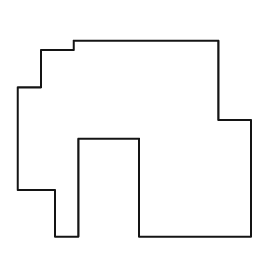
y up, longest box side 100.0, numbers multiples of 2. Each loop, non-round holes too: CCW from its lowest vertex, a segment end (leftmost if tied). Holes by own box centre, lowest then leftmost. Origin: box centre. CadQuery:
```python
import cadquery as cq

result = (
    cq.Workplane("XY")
    .moveTo(-34.0, -42.0)
    .lineTo(-24.0, -42.0)
    .lineTo(-24.0, 0.0)
    .lineTo(2.0, 0.0)
    .lineTo(2.0, -42.0)
    .lineTo(50.0, -42.0)
    .lineTo(50.0, 8.0)
    .lineTo(36.0, 8.0)
    .lineTo(36.0, 42.0)
    .lineTo(-26.0, 42.0)
    .lineTo(-26.0, 38.0)
    .lineTo(-40.0, 38.0)
    .lineTo(-40.0, 22.0)
    .lineTo(-50.0, 22.0)
    .lineTo(-50.0, -22.0)
    .lineTo(-34.0, -22.0)
    .close()
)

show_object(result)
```